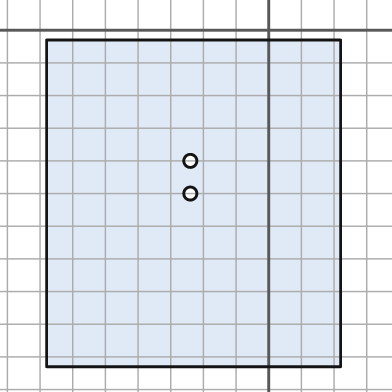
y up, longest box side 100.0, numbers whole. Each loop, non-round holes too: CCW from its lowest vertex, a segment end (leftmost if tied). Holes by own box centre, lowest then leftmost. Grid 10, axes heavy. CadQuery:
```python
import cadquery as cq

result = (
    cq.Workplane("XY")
    .moveTo(-68.0, -103.0)
    .lineTo(22.0, -103.0)
    .lineTo(22.0, -3.0)
    .lineTo(-68.0, -3.0)
    .close()
    .moveTo(-24.0, -50.0)
    .circle(2.0)
    .moveTo(-24.0, -40.0)
    .circle(2.0)
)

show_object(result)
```